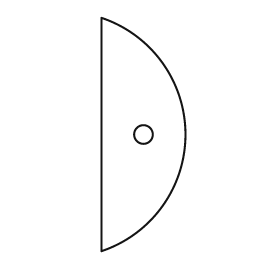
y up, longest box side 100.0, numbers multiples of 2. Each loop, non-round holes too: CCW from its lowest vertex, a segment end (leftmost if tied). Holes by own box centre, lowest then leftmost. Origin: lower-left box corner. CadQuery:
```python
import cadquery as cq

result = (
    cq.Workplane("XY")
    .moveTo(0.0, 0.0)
    .threePointArc((36.0, 50.0), (0.0, 100.0))
    .close()
    .moveTo(18.0, 50.0)
    .circle(4.0)
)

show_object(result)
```